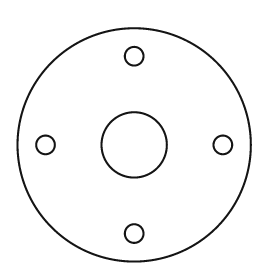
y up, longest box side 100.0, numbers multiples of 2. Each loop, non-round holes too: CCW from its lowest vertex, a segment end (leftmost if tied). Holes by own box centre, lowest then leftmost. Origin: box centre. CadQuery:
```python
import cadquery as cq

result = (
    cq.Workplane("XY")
    .moveTo(0.0, 0.0)
    .circle(50.0)
    .moveTo(0.0, -38.0)
    .circle(4.0)
    .moveTo(-38.0, 0.0)
    .circle(4.0)
    .moveTo(0.0, 0.0)
    .circle(14.0)
    .moveTo(38.0, 0.0)
    .circle(4.0)
    .moveTo(0.0, 38.0)
    .circle(4.0)
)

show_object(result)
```